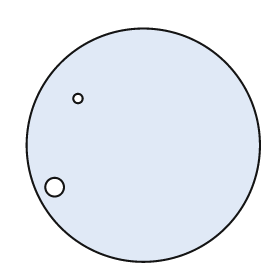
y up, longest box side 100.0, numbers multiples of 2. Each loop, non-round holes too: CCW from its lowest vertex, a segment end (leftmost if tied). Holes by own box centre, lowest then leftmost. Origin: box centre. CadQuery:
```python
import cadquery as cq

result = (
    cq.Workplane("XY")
    .moveTo(0.0, 0.0)
    .circle(50.0)
    .moveTo(-38.0, -18.0)
    .circle(4.0)
    .moveTo(-28.0, 20.0)
    .circle(2.0)
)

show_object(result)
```